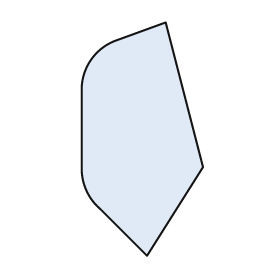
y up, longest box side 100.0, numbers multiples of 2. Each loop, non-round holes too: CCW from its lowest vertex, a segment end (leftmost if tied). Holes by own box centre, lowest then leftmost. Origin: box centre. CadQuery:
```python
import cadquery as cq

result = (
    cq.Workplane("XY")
    .moveTo(2.0, -50.0)
    .lineTo(26.0, -12.0)
    .lineTo(10.0, 50.0)
    .lineTo(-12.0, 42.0)
    .threePointArc((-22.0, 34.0), (-26.0, 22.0))
    .lineTo(-26.0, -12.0)
    .threePointArc((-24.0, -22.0), (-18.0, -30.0))
    .close()
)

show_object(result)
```